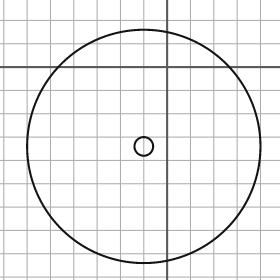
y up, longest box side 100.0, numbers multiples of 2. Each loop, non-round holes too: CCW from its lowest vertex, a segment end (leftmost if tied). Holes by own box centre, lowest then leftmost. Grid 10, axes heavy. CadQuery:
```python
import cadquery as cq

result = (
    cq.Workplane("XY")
    .moveTo(-10.0, -34.0)
    .circle(50.0)
    .moveTo(-10.0, -34.0)
    .circle(4.0)
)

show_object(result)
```